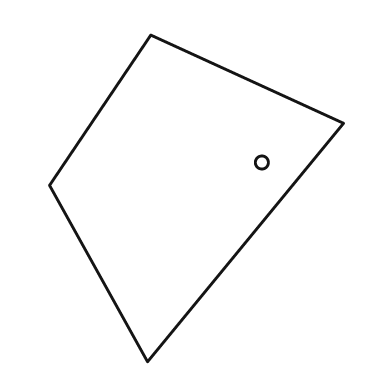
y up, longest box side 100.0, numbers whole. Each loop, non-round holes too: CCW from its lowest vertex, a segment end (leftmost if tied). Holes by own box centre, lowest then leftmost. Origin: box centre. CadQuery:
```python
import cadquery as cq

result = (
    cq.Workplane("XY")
    .moveTo(-15.0, -50.0)
    .lineTo(45.0, 23.0)
    .lineTo(-14.0, 50.0)
    .lineTo(-45.0, 4.0)
    .close()
    .moveTo(20.0, 11.0)
    .circle(2.0)
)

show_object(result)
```